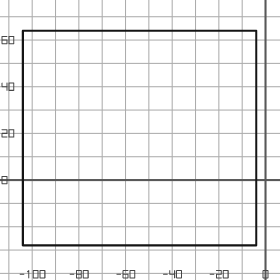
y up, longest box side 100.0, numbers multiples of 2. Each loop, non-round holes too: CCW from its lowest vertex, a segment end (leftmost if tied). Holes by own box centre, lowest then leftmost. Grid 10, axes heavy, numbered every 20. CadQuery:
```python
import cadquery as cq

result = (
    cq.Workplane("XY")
    .moveTo(-104.0, -28.0)
    .lineTo(-4.0, -28.0)
    .lineTo(-4.0, 64.0)
    .lineTo(-104.0, 64.0)
    .close()
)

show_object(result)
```